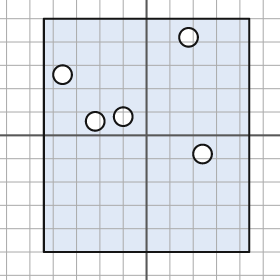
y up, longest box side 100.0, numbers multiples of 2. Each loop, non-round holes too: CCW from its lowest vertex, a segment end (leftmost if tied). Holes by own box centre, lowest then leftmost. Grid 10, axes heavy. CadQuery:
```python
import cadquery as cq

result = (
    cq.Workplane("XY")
    .moveTo(-44.0, -50.0)
    .lineTo(44.0, -50.0)
    .lineTo(44.0, 50.0)
    .lineTo(-44.0, 50.0)
    .close()
    .moveTo(24.0, -8.0)
    .circle(4.0)
    .moveTo(-22.0, 6.0)
    .circle(4.0)
    .moveTo(-10.0, 8.0)
    .circle(4.0)
    .moveTo(-36.0, 26.0)
    .circle(4.0)
    .moveTo(18.0, 42.0)
    .circle(4.0)
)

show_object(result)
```